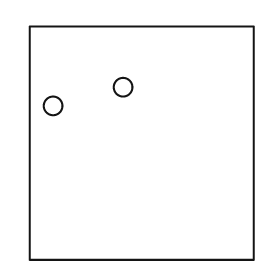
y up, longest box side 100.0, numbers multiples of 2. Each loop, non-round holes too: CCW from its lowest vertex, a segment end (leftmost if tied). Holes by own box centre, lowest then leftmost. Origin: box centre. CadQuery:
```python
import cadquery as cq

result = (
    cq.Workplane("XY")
    .moveTo(-48.0, -50.0)
    .lineTo(48.0, -50.0)
    .lineTo(48.0, 50.0)
    .lineTo(-48.0, 50.0)
    .close()
    .moveTo(-38.0, 16.0)
    .circle(4.0)
    .moveTo(-8.0, 24.0)
    .circle(4.0)
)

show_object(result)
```